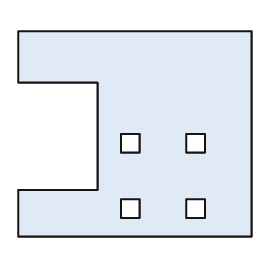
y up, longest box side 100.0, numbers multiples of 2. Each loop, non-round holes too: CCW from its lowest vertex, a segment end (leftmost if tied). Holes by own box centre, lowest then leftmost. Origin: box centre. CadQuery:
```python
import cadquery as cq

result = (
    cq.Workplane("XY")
    .moveTo(-50.0, -44.0)
    .lineTo(50.0, -44.0)
    .lineTo(50.0, 44.0)
    .lineTo(-50.0, 44.0)
    .lineTo(-50.0, 22.0)
    .lineTo(-16.0, 22.0)
    .lineTo(-16.0, -24.0)
    .lineTo(-50.0, -24.0)
    .close()
    .moveTo(-6.0, -36.0)
    .lineTo(2.0, -36.0)
    .lineTo(2.0, -28.0)
    .lineTo(-6.0, -28.0)
    .close()
    .moveTo(22.0, -36.0)
    .lineTo(30.0, -36.0)
    .lineTo(30.0, -28.0)
    .lineTo(22.0, -28.0)
    .close()
    .moveTo(-6.0, -8.0)
    .lineTo(2.0, -8.0)
    .lineTo(2.0, 0.0)
    .lineTo(-6.0, 0.0)
    .close()
    .moveTo(22.0, -8.0)
    .lineTo(30.0, -8.0)
    .lineTo(30.0, 0.0)
    .lineTo(22.0, 0.0)
    .close()
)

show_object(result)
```